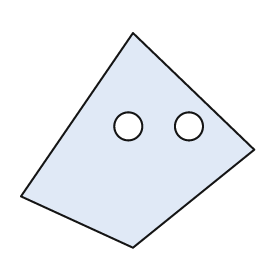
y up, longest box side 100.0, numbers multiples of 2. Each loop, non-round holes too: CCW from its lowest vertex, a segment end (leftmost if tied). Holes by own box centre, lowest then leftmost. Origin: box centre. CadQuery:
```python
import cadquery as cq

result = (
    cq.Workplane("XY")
    .moveTo(-2.0, -46.0)
    .lineTo(50.0, -4.0)
    .lineTo(-2.0, 46.0)
    .lineTo(-50.0, -24.0)
    .close()
    .moveTo(-4.0, 6.0)
    .circle(6.0)
    .moveTo(22.0, 6.0)
    .circle(6.0)
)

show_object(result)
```